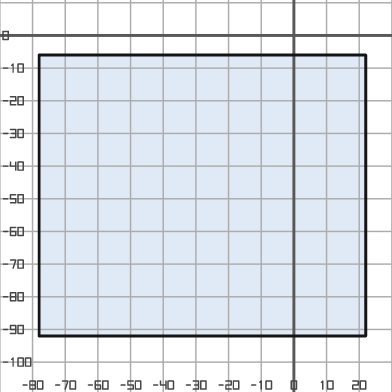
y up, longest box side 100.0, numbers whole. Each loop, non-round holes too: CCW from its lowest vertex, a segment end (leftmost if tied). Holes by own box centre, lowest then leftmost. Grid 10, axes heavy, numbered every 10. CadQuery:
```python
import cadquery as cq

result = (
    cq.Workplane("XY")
    .moveTo(-78.0, -92.0)
    .lineTo(22.0, -92.0)
    .lineTo(22.0, -6.0)
    .lineTo(-78.0, -6.0)
    .close()
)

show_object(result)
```